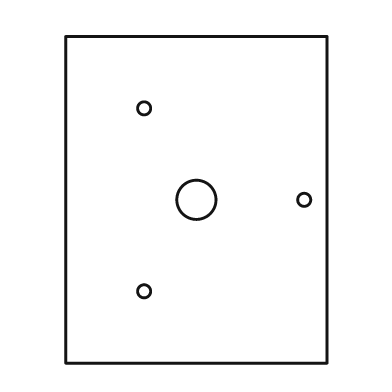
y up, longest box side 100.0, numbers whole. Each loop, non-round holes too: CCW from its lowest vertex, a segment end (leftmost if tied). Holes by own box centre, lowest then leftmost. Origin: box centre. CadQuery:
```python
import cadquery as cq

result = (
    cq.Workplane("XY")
    .moveTo(-40.0, -50.0)
    .lineTo(40.0, -50.0)
    .lineTo(40.0, 50.0)
    .lineTo(-40.0, 50.0)
    .close()
    .moveTo(-16.0, -28.0)
    .circle(2.0)
    .moveTo(0.0, 0.0)
    .circle(6.0)
    .moveTo(33.0, 0.0)
    .circle(2.0)
    .moveTo(-16.0, 28.0)
    .circle(2.0)
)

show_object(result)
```